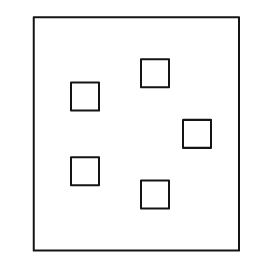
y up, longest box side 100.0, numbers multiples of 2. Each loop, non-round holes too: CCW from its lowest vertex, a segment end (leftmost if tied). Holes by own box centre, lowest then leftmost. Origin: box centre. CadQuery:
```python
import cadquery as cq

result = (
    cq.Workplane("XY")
    .moveTo(-44.0, -50.0)
    .lineTo(44.0, -50.0)
    .lineTo(44.0, 50.0)
    .lineTo(-44.0, 50.0)
    .close()
    .moveTo(2.0, -32.0)
    .lineTo(14.0, -32.0)
    .lineTo(14.0, -20.0)
    .lineTo(2.0, -20.0)
    .close()
    .moveTo(-28.0, -22.0)
    .lineTo(-16.0, -22.0)
    .lineTo(-16.0, -10.0)
    .lineTo(-28.0, -10.0)
    .close()
    .moveTo(20.0, -6.0)
    .lineTo(32.0, -6.0)
    .lineTo(32.0, 6.0)
    .lineTo(20.0, 6.0)
    .close()
    .moveTo(-28.0, 10.0)
    .lineTo(-16.0, 10.0)
    .lineTo(-16.0, 22.0)
    .lineTo(-28.0, 22.0)
    .close()
    .moveTo(2.0, 20.0)
    .lineTo(14.0, 20.0)
    .lineTo(14.0, 32.0)
    .lineTo(2.0, 32.0)
    .close()
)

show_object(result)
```